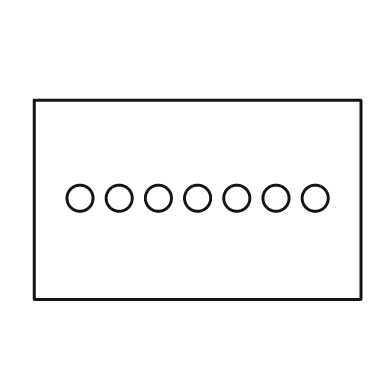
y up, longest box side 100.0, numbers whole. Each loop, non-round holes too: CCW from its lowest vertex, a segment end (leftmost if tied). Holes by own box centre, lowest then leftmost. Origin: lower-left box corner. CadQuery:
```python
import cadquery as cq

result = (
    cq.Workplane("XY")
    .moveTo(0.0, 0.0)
    .lineTo(100.0, 0.0)
    .lineTo(100.0, 61.0)
    .lineTo(0.0, 61.0)
    .close()
    .moveTo(14.0, 31.0)
    .circle(4.0)
    .moveTo(26.0, 31.0)
    .circle(4.0)
    .moveTo(38.0, 31.0)
    .circle(4.0)
    .moveTo(50.0, 31.0)
    .circle(4.0)
    .moveTo(62.0, 31.0)
    .circle(4.0)
    .moveTo(74.0, 31.0)
    .circle(4.0)
    .moveTo(86.0, 31.0)
    .circle(4.0)
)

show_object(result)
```